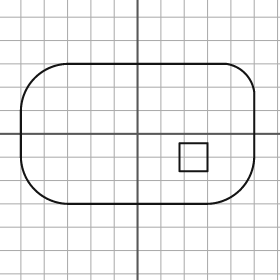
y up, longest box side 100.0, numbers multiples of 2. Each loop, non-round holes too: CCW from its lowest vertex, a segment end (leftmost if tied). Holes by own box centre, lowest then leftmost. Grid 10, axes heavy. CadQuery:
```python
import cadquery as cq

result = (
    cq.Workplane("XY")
    .moveTo(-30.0, -30.0)
    .lineTo(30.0, -30.0)
    .threePointArc((44.0, -24.0), (50.0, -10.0))
    .lineTo(50.0, 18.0)
    .threePointArc((46.0, 26.0), (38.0, 30.0))
    .lineTo(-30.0, 30.0)
    .threePointArc((-44.0, 24.0), (-50.0, 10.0))
    .lineTo(-50.0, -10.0)
    .threePointArc((-44.0, -24.0), (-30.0, -30.0))
    .close()
    .moveTo(18.0, -16.0)
    .lineTo(30.0, -16.0)
    .lineTo(30.0, -4.0)
    .lineTo(18.0, -4.0)
    .close()
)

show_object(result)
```